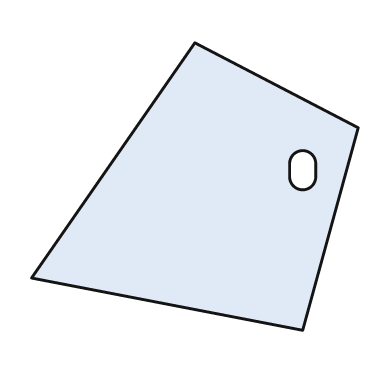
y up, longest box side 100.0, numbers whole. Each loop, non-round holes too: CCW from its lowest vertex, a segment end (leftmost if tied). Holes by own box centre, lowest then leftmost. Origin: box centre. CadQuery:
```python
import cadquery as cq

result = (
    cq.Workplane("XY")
    .moveTo(33.0, -44.0)
    .lineTo(50.0, 18.0)
    .lineTo(0.0, 44.0)
    .lineTo(-50.0, -28.0)
    .close()
    .moveTo(29.0, 3.0)
    .threePointArc((33.0, -1.0), (37.0, 3.0))
    .lineTo(37.0, 7.0)
    .threePointArc((33.0, 11.0), (29.0, 7.0))
    .close()
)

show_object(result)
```